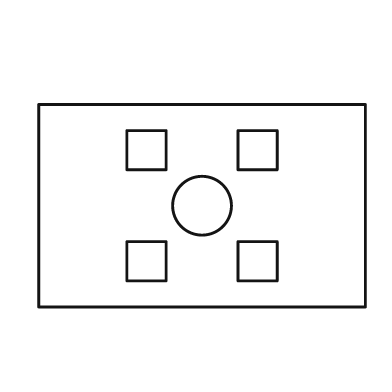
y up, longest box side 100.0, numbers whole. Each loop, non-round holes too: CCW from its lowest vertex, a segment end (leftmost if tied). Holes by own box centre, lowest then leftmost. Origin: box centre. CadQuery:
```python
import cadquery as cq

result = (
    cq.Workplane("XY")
    .moveTo(-50.0, -31.0)
    .lineTo(50.0, -31.0)
    .lineTo(50.0, 31.0)
    .lineTo(-50.0, 31.0)
    .close()
    .moveTo(-23.0, -23.0)
    .lineTo(-11.0, -23.0)
    .lineTo(-11.0, -11.0)
    .lineTo(-23.0, -11.0)
    .close()
    .moveTo(11.0, -23.0)
    .lineTo(23.0, -23.0)
    .lineTo(23.0, -11.0)
    .lineTo(11.0, -11.0)
    .close()
    .moveTo(0.0, 0.0)
    .circle(9.0)
    .moveTo(-23.0, 11.0)
    .lineTo(-11.0, 11.0)
    .lineTo(-11.0, 23.0)
    .lineTo(-23.0, 23.0)
    .close()
    .moveTo(11.0, 11.0)
    .lineTo(23.0, 11.0)
    .lineTo(23.0, 23.0)
    .lineTo(11.0, 23.0)
    .close()
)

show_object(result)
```